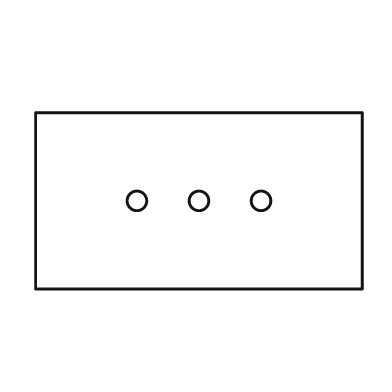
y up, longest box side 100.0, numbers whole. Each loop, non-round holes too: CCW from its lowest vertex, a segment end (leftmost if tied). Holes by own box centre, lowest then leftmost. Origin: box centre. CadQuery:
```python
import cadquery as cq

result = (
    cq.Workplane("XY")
    .moveTo(-50.0, -27.0)
    .lineTo(50.0, -27.0)
    .lineTo(50.0, 27.0)
    .lineTo(-50.0, 27.0)
    .close()
    .moveTo(-19.0, 0.0)
    .circle(3.0)
    .moveTo(0.0, 0.0)
    .circle(3.0)
    .moveTo(19.0, 0.0)
    .circle(3.0)
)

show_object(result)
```